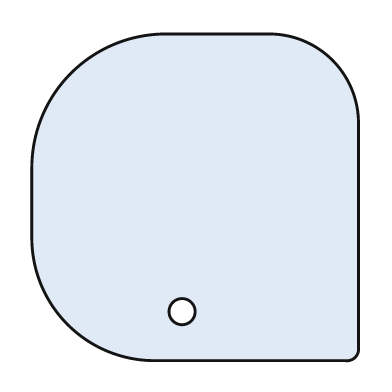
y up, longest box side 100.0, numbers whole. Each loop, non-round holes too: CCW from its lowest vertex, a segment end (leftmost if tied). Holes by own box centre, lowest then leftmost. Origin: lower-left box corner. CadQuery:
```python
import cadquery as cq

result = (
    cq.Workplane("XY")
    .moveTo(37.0, 0.0)
    .lineTo(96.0, 0.0)
    .threePointArc((99.0, 1.0), (100.0, 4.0))
    .lineTo(100.0, 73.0)
    .threePointArc((92.0, 92.0), (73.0, 100.0))
    .lineTo(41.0, 100.0)
    .threePointArc((12.0, 88.0), (0.0, 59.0))
    .lineTo(0.0, 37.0)
    .threePointArc((11.0, 11.0), (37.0, 0.0))
    .close()
    .moveTo(46.0, 15.0)
    .circle(4.0)
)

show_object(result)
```